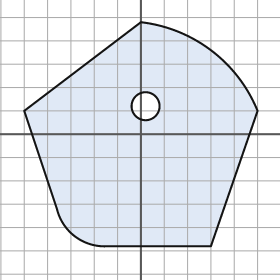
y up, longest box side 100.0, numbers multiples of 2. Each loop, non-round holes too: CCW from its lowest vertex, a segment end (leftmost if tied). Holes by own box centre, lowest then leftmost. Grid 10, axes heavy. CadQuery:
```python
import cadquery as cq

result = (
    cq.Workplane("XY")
    .moveTo(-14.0, -48.0)
    .lineTo(30.0, -48.0)
    .lineTo(50.0, 10.0)
    .threePointArc((30.0, 36.0), (0.0, 48.0))
    .lineTo(-50.0, 10.0)
    .lineTo(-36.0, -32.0)
    .threePointArc((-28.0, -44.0), (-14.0, -48.0))
    .close()
    .moveTo(2.0, 12.0)
    .circle(6.0)
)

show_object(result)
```